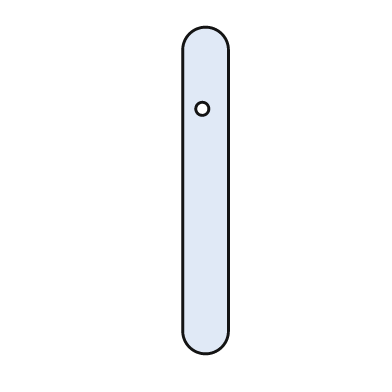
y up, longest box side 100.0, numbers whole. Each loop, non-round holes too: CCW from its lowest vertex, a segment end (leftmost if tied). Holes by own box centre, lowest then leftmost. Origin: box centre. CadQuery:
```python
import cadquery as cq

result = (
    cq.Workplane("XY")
    .moveTo(-7.0, -43.0)
    .threePointArc((0.0, -50.0), (7.0, -43.0))
    .lineTo(7.0, 43.0)
    .threePointArc((0.0, 50.0), (-7.0, 43.0))
    .close()
    .moveTo(-1.0, 25.0)
    .circle(2.0)
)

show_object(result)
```